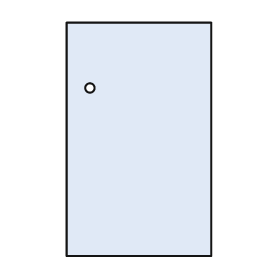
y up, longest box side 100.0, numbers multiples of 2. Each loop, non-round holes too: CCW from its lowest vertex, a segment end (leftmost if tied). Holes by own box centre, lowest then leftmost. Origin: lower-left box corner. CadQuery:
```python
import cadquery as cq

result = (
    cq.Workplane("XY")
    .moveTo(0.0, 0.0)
    .lineTo(62.0, 0.0)
    .lineTo(62.0, 100.0)
    .lineTo(0.0, 100.0)
    .close()
    .moveTo(10.0, 72.0)
    .circle(2.0)
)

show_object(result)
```